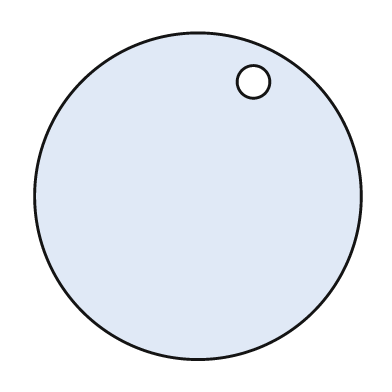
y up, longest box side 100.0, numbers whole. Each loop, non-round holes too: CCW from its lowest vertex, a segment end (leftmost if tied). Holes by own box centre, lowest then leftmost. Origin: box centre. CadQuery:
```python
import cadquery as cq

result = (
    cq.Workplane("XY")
    .moveTo(0.0, 0.0)
    .circle(50.0)
    .moveTo(17.0, 35.0)
    .circle(5.0)
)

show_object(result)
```